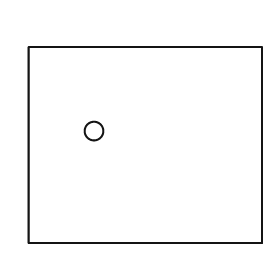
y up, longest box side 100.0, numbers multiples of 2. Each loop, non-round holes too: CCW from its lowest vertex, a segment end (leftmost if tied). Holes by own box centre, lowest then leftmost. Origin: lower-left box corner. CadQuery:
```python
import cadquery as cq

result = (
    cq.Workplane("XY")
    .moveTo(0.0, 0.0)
    .lineTo(100.0, 0.0)
    .lineTo(100.0, 84.0)
    .lineTo(0.0, 84.0)
    .close()
    .moveTo(28.0, 48.0)
    .circle(4.0)
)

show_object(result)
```